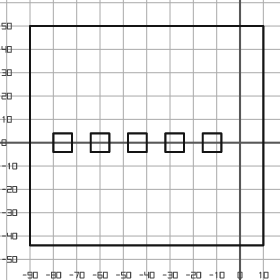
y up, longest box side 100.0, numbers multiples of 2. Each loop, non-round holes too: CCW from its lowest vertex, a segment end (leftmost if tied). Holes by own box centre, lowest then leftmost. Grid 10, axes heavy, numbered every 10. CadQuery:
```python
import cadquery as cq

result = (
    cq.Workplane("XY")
    .moveTo(-90.0, -44.0)
    .lineTo(10.0, -44.0)
    .lineTo(10.0, 50.0)
    .lineTo(-90.0, 50.0)
    .close()
    .moveTo(-80.0, -4.0)
    .lineTo(-72.0, -4.0)
    .lineTo(-72.0, 4.0)
    .lineTo(-80.0, 4.0)
    .close()
    .moveTo(-64.0, -4.0)
    .lineTo(-56.0, -4.0)
    .lineTo(-56.0, 4.0)
    .lineTo(-64.0, 4.0)
    .close()
    .moveTo(-48.0, -4.0)
    .lineTo(-40.0, -4.0)
    .lineTo(-40.0, 4.0)
    .lineTo(-48.0, 4.0)
    .close()
    .moveTo(-32.0, -4.0)
    .lineTo(-24.0, -4.0)
    .lineTo(-24.0, 4.0)
    .lineTo(-32.0, 4.0)
    .close()
    .moveTo(-16.0, -4.0)
    .lineTo(-8.0, -4.0)
    .lineTo(-8.0, 4.0)
    .lineTo(-16.0, 4.0)
    .close()
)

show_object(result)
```